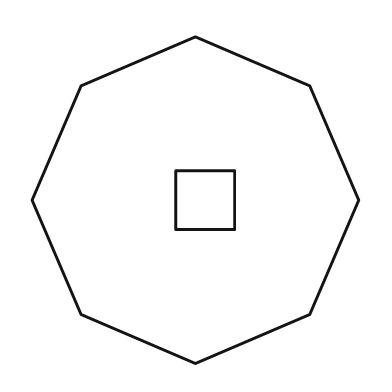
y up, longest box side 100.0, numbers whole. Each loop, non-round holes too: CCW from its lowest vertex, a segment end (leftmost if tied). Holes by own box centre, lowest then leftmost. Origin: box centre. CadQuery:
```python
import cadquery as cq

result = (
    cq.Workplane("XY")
    .moveTo(0.0, -50.0)
    .lineTo(35.0, -35.0)
    .lineTo(50.0, 0.0)
    .lineTo(35.0, 35.0)
    .lineTo(0.0, 50.0)
    .lineTo(-35.0, 35.0)
    .lineTo(-50.0, 0.0)
    .lineTo(-35.0, -35.0)
    .close()
    .moveTo(-6.0, -9.0)
    .lineTo(12.0, -9.0)
    .lineTo(12.0, 9.0)
    .lineTo(-6.0, 9.0)
    .close()
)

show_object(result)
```